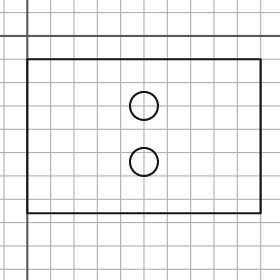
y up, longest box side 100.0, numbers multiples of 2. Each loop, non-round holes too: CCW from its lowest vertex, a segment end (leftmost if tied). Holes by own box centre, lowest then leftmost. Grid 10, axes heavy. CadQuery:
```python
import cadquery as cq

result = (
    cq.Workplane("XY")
    .moveTo(0.0, -76.0)
    .lineTo(100.0, -76.0)
    .lineTo(100.0, -10.0)
    .lineTo(0.0, -10.0)
    .close()
    .moveTo(50.0, -54.0)
    .circle(6.0)
    .moveTo(50.0, -30.0)
    .circle(6.0)
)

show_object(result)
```